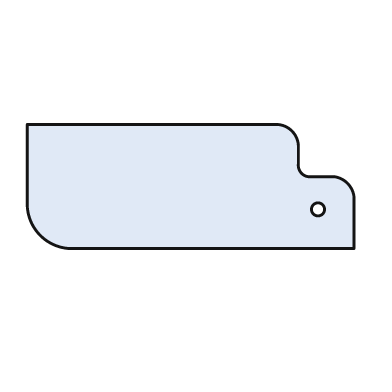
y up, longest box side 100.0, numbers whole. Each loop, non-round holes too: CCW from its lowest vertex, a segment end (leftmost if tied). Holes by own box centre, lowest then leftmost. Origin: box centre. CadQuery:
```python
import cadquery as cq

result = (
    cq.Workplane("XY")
    .moveTo(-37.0, -19.0)
    .lineTo(50.0, -19.0)
    .lineTo(50.0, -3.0)
    .threePointArc((48.0, 1.0), (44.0, 3.0))
    .lineTo(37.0, 3.0)
    .threePointArc((34.0, 4.0), (33.0, 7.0))
    .lineTo(33.0, 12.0)
    .threePointArc((31.0, 17.0), (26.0, 19.0))
    .lineTo(-50.0, 19.0)
    .lineTo(-50.0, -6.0)
    .threePointArc((-46.0, -15.0), (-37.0, -19.0))
    .close()
    .moveTo(39.0, -7.0)
    .circle(2.0)
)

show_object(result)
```